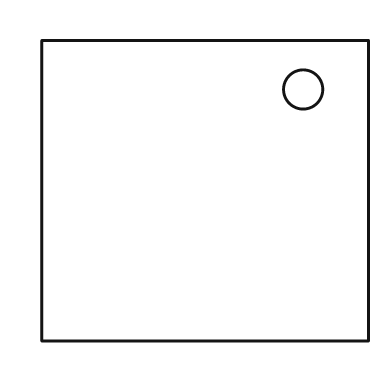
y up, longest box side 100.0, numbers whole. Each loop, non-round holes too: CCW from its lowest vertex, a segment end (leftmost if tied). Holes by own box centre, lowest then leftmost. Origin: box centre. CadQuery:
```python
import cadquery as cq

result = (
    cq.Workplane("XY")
    .moveTo(-50.0, -46.0)
    .lineTo(50.0, -46.0)
    .lineTo(50.0, 46.0)
    .lineTo(-50.0, 46.0)
    .close()
    .moveTo(30.0, 31.0)
    .circle(6.0)
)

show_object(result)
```